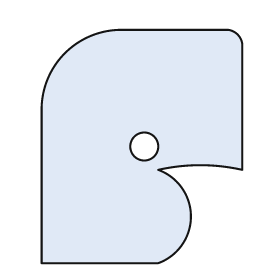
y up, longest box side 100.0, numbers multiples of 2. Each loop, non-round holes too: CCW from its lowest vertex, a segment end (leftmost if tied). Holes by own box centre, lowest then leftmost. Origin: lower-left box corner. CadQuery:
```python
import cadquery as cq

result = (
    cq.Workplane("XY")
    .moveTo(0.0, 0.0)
    .lineTo(50.0, 0.0)
    .threePointArc((64.0, 20.0), (50.0, 40.0))
    .threePointArc((68.0, 42.0), (86.0, 40.0))
    .lineTo(86.0, 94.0)
    .threePointArc((84.0, 98.0), (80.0, 100.0))
    .lineTo(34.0, 100.0)
    .threePointArc((10.0, 90.0), (0.0, 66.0))
    .close()
    .moveTo(44.0, 50.0)
    .circle(6.0)
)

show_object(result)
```